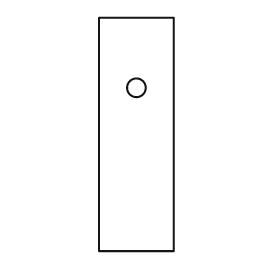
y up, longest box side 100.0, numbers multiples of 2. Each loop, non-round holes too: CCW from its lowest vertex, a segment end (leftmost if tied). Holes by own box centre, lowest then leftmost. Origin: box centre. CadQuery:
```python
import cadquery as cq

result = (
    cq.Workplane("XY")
    .moveTo(-16.0, -50.0)
    .lineTo(16.0, -50.0)
    .lineTo(16.0, 50.0)
    .lineTo(-16.0, 50.0)
    .close()
    .moveTo(0.0, 20.0)
    .circle(4.0)
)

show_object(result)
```